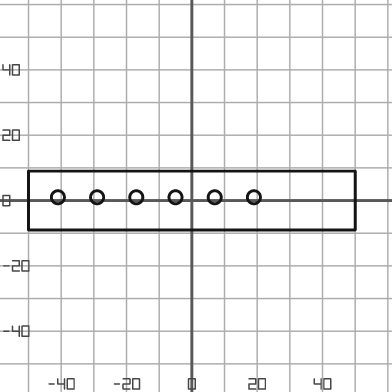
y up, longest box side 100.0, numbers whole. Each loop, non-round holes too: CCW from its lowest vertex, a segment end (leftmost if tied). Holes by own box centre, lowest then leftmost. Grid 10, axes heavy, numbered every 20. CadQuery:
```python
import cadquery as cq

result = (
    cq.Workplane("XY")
    .moveTo(-50.0, -9.0)
    .lineTo(50.0, -9.0)
    .lineTo(50.0, 9.0)
    .lineTo(-50.0, 9.0)
    .close()
    .moveTo(-41.0, 1.0)
    .circle(2.0)
    .moveTo(-29.0, 1.0)
    .circle(2.0)
    .moveTo(-17.0, 1.0)
    .circle(2.0)
    .moveTo(-5.0, 1.0)
    .circle(2.0)
    .moveTo(7.0, 1.0)
    .circle(2.0)
    .moveTo(19.0, 1.0)
    .circle(2.0)
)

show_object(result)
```